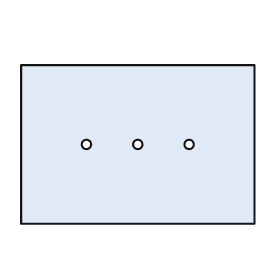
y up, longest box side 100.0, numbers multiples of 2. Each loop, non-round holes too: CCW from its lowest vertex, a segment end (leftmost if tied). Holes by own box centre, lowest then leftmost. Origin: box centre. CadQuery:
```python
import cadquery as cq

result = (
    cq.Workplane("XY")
    .moveTo(-50.0, -34.0)
    .lineTo(50.0, -34.0)
    .lineTo(50.0, 34.0)
    .lineTo(-50.0, 34.0)
    .close()
    .moveTo(-22.0, 0.0)
    .circle(2.0)
    .moveTo(0.0, 0.0)
    .circle(2.0)
    .moveTo(22.0, 0.0)
    .circle(2.0)
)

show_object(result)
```